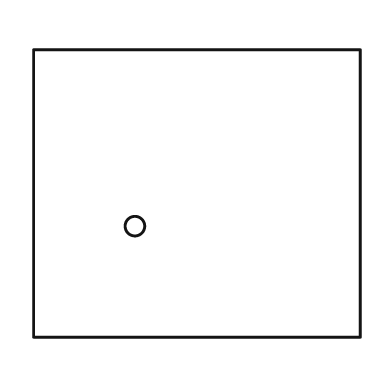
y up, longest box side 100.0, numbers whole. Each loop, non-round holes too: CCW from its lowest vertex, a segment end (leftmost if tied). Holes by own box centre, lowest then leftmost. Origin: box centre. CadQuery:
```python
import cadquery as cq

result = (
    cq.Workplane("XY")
    .moveTo(-50.0, -44.0)
    .lineTo(50.0, -44.0)
    .lineTo(50.0, 44.0)
    .lineTo(-50.0, 44.0)
    .close()
    .moveTo(-19.0, -10.0)
    .circle(3.0)
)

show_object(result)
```